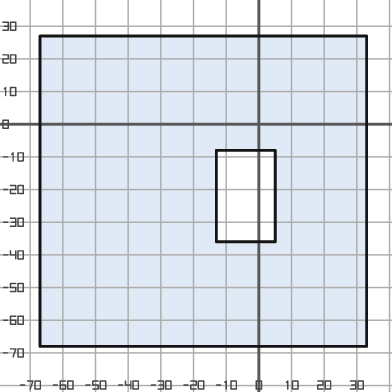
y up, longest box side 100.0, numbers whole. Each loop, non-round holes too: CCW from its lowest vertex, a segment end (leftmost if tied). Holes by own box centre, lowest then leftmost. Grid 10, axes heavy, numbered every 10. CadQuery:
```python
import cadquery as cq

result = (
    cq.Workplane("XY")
    .moveTo(-67.0, -68.0)
    .lineTo(33.0, -68.0)
    .lineTo(33.0, 27.0)
    .lineTo(-67.0, 27.0)
    .close()
    .moveTo(-13.0, -36.0)
    .lineTo(5.0, -36.0)
    .lineTo(5.0, -8.0)
    .lineTo(-13.0, -8.0)
    .close()
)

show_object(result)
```